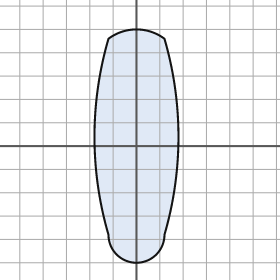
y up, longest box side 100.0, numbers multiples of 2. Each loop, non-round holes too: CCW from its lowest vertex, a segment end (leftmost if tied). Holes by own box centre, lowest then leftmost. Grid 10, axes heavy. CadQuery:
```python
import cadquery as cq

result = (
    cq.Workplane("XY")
    .moveTo(-12.0, -38.0)
    .threePointArc((0.0, -50.0), (12.0, -38.0))
    .threePointArc((18.0, 4.0), (12.0, 46.0))
    .threePointArc((0.0, 50.0), (-12.0, 46.0))
    .threePointArc((-18.0, 4.0), (-12.0, -38.0))
    .close()
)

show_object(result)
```